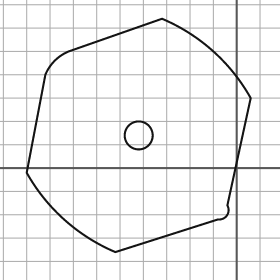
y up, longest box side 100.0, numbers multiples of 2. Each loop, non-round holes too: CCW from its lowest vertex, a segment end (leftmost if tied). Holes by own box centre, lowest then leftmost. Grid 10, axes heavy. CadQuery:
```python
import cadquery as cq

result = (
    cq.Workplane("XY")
    .moveTo(-52.0, -36.0)
    .lineTo(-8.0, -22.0)
    .threePointArc((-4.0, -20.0), (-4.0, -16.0))
    .lineTo(6.0, 30.0)
    .threePointArc((-10.0, 50.0), (-32.0, 64.0))
    .lineTo(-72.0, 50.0)
    .threePointArc((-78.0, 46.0), (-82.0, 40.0))
    .lineTo(-90.0, -2.0)
    .threePointArc((-74.0, -22.0), (-52.0, -36.0))
    .close()
    .moveTo(-42.0, 14.0)
    .circle(6.0)
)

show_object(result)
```